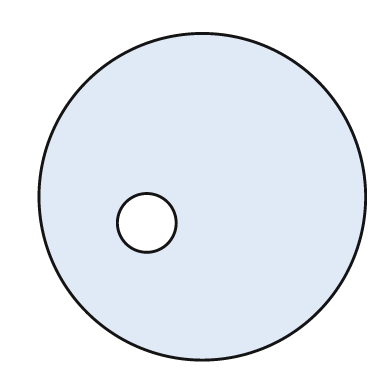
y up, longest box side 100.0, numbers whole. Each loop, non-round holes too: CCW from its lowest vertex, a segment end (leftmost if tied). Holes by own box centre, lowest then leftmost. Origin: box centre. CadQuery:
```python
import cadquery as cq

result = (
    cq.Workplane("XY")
    .moveTo(0.0, 0.0)
    .circle(50.0)
    .moveTo(-17.0, -8.0)
    .circle(9.0)
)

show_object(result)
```